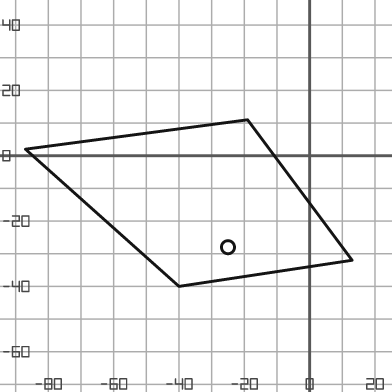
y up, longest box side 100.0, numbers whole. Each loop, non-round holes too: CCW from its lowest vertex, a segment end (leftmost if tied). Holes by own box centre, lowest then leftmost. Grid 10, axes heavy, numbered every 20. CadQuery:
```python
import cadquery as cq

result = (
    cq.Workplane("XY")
    .moveTo(-40.0, -40.0)
    .lineTo(13.0, -32.0)
    .lineTo(-19.0, 11.0)
    .lineTo(-87.0, 2.0)
    .close()
    .moveTo(-25.0, -28.0)
    .circle(2.0)
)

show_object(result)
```